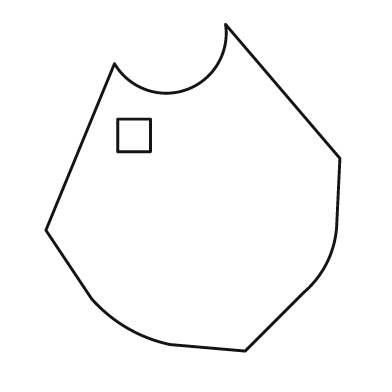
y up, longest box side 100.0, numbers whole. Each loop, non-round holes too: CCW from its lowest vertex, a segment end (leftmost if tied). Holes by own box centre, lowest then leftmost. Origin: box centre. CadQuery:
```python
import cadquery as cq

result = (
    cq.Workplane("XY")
    .moveTo(16.0, -50.0)
    .lineTo(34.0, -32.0)
    .threePointArc((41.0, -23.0), (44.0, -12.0))
    .lineTo(45.0, 9.0)
    .lineTo(10.0, 50.0)
    .threePointArc((-2.0, 30.0), (-24.0, 38.0))
    .lineTo(-45.0, -13.0)
    .lineTo(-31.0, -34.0)
    .threePointArc((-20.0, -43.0), (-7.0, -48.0))
    .close()
    .moveTo(-23.0, 11.0)
    .lineTo(-13.0, 11.0)
    .lineTo(-13.0, 21.0)
    .lineTo(-23.0, 21.0)
    .close()
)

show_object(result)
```